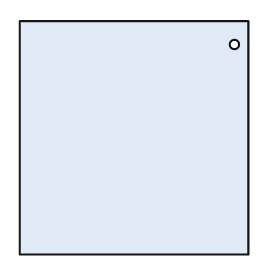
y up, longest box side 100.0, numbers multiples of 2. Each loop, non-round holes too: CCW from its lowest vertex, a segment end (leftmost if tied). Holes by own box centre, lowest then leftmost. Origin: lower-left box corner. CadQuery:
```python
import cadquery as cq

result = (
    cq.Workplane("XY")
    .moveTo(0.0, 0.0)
    .lineTo(98.0, 0.0)
    .lineTo(98.0, 100.0)
    .lineTo(0.0, 100.0)
    .close()
    .moveTo(92.0, 90.0)
    .circle(2.0)
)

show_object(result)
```